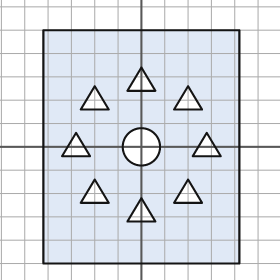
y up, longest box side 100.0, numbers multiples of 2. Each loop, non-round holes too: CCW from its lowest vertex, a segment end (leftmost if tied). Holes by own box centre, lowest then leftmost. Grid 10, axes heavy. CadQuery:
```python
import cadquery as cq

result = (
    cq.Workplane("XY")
    .moveTo(-42.0, -50.0)
    .lineTo(42.0, -50.0)
    .lineTo(42.0, 50.0)
    .lineTo(-42.0, 50.0)
    .close()
    .moveTo(-6.0, -32.0)
    .lineTo(6.0, -32.0)
    .lineTo(0.0, -22.0)
    .close()
    .moveTo(-26.0, -24.0)
    .lineTo(-14.0, -24.0)
    .lineTo(-20.0, -14.0)
    .close()
    .moveTo(14.0, -24.0)
    .lineTo(26.0, -24.0)
    .lineTo(20.0, -14.0)
    .close()
    .moveTo(0.0, 0.0)
    .circle(8.0)
    .moveTo(-34.0, -4.0)
    .lineTo(-22.0, -4.0)
    .lineTo(-28.0, 6.0)
    .close()
    .moveTo(22.0, -4.0)
    .lineTo(34.0, -4.0)
    .lineTo(28.0, 6.0)
    .close()
    .moveTo(-26.0, 16.0)
    .lineTo(-14.0, 16.0)
    .lineTo(-20.0, 26.0)
    .close()
    .moveTo(14.0, 16.0)
    .lineTo(26.0, 16.0)
    .lineTo(20.0, 26.0)
    .close()
    .moveTo(-6.0, 24.0)
    .lineTo(6.0, 24.0)
    .lineTo(0.0, 34.0)
    .close()
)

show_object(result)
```